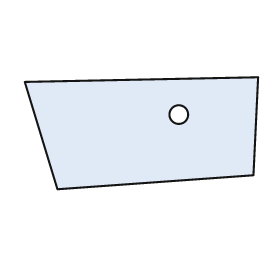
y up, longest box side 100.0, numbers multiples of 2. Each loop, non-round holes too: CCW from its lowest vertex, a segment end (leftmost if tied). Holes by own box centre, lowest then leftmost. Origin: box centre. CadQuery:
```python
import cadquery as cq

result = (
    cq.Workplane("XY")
    .moveTo(-36.0, -24.0)
    .lineTo(48.0, -18.0)
    .lineTo(50.0, 24.0)
    .lineTo(-50.0, 22.0)
    .close()
    .moveTo(16.0, 8.0)
    .circle(4.0)
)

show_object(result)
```